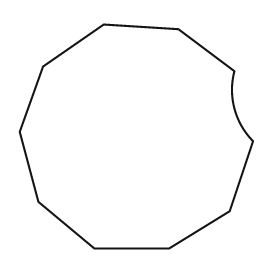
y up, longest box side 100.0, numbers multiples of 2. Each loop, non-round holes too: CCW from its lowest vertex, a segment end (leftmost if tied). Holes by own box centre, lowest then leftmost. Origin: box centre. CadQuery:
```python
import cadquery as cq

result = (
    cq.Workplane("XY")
    .moveTo(-18.0, -48.0)
    .lineTo(14.0, -48.0)
    .lineTo(40.0, -32.0)
    .lineTo(50.0, -2.0)
    .threePointArc((42.0, 12.0), (42.0, 28.0))
    .lineTo(18.0, 46.0)
    .lineTo(-14.0, 48.0)
    .lineTo(-40.0, 30.0)
    .lineTo(-50.0, 2.0)
    .lineTo(-42.0, -28.0)
    .close()
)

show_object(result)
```